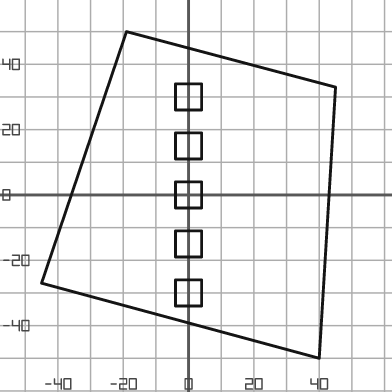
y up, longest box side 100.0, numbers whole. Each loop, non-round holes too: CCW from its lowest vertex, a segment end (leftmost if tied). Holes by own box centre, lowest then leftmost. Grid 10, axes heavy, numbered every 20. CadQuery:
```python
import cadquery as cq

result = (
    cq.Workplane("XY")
    .moveTo(40.0, -50.0)
    .lineTo(45.0, 33.0)
    .lineTo(-19.0, 50.0)
    .lineTo(-45.0, -27.0)
    .close()
    .moveTo(-4.0, -34.0)
    .lineTo(4.0, -34.0)
    .lineTo(4.0, -26.0)
    .lineTo(-4.0, -26.0)
    .close()
    .moveTo(-4.0, -19.0)
    .lineTo(4.0, -19.0)
    .lineTo(4.0, -11.0)
    .lineTo(-4.0, -11.0)
    .close()
    .moveTo(-4.0, -4.0)
    .lineTo(4.0, -4.0)
    .lineTo(4.0, 4.0)
    .lineTo(-4.0, 4.0)
    .close()
    .moveTo(-4.0, 11.0)
    .lineTo(4.0, 11.0)
    .lineTo(4.0, 19.0)
    .lineTo(-4.0, 19.0)
    .close()
    .moveTo(-4.0, 26.0)
    .lineTo(4.0, 26.0)
    .lineTo(4.0, 34.0)
    .lineTo(-4.0, 34.0)
    .close()
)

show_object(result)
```